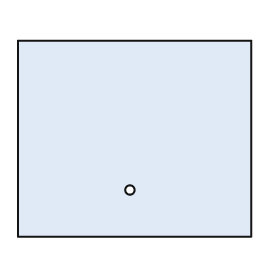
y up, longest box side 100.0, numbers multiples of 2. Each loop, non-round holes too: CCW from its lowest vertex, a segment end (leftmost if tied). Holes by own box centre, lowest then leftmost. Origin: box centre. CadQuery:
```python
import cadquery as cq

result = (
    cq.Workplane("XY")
    .moveTo(-50.0, -42.0)
    .lineTo(50.0, -42.0)
    .lineTo(50.0, 42.0)
    .lineTo(-50.0, 42.0)
    .close()
    .moveTo(-2.0, -22.0)
    .circle(2.0)
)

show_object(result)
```